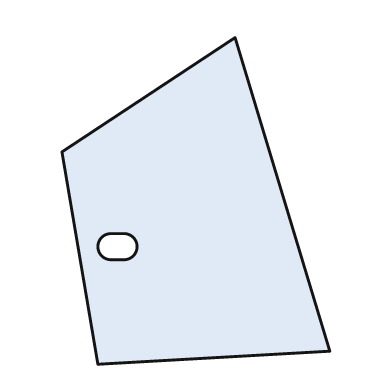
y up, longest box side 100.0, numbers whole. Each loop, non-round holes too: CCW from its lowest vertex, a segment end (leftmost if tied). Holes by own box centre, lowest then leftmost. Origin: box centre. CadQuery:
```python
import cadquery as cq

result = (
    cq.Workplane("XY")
    .moveTo(-30.0, -50.0)
    .lineTo(41.0, -46.0)
    .lineTo(12.0, 50.0)
    .lineTo(-41.0, 15.0)
    .close()
    .moveTo(-26.0, -18.0)
    .lineTo(-22.0, -18.0)
    .threePointArc((-18.0, -14.0), (-22.0, -10.0))
    .lineTo(-26.0, -10.0)
    .threePointArc((-30.0, -14.0), (-26.0, -18.0))
    .close()
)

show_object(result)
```